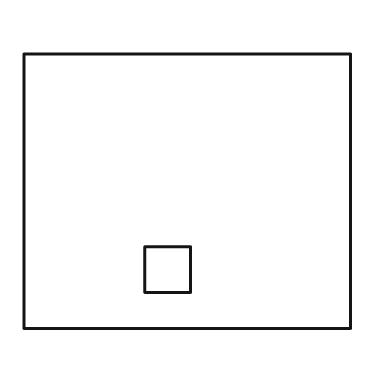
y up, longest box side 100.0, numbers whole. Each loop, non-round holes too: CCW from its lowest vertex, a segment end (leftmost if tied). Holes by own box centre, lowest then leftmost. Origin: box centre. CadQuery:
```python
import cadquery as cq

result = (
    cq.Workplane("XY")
    .moveTo(-50.0, -42.0)
    .lineTo(50.0, -42.0)
    .lineTo(50.0, 42.0)
    .lineTo(-50.0, 42.0)
    .close()
    .moveTo(-13.0, -31.0)
    .lineTo(1.0, -31.0)
    .lineTo(1.0, -17.0)
    .lineTo(-13.0, -17.0)
    .close()
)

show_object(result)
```